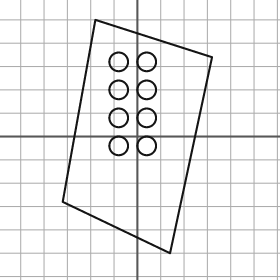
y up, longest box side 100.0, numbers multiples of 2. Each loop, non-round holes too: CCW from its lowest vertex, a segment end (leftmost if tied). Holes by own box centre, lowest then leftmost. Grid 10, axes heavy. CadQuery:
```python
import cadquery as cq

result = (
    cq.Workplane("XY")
    .moveTo(14.0, -50.0)
    .lineTo(32.0, 34.0)
    .lineTo(-18.0, 50.0)
    .lineTo(-32.0, -28.0)
    .close()
    .moveTo(-8.0, -4.0)
    .circle(4.0)
    .moveTo(4.0, -4.0)
    .circle(4.0)
    .moveTo(-8.0, 8.0)
    .circle(4.0)
    .moveTo(4.0, 8.0)
    .circle(4.0)
    .moveTo(-8.0, 20.0)
    .circle(4.0)
    .moveTo(4.0, 20.0)
    .circle(4.0)
    .moveTo(-8.0, 32.0)
    .circle(4.0)
    .moveTo(4.0, 32.0)
    .circle(4.0)
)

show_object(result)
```